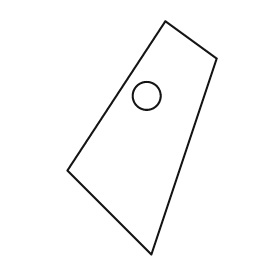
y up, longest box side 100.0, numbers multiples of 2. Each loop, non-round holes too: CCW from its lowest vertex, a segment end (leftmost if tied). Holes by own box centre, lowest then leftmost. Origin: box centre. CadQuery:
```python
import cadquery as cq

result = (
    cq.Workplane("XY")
    .moveTo(4.0, -50.0)
    .lineTo(32.0, 34.0)
    .lineTo(10.0, 50.0)
    .lineTo(-32.0, -14.0)
    .close()
    .moveTo(2.0, 18.0)
    .circle(6.0)
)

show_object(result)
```